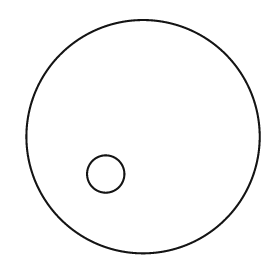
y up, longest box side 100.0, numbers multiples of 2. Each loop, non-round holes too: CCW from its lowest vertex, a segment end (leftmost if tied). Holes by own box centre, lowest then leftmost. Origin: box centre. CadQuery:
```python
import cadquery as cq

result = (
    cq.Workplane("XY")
    .moveTo(0.0, 0.0)
    .circle(50.0)
    .moveTo(-16.0, -16.0)
    .circle(8.0)
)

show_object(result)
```